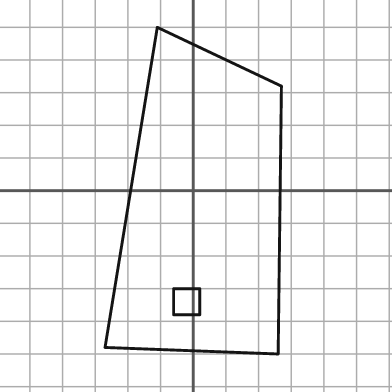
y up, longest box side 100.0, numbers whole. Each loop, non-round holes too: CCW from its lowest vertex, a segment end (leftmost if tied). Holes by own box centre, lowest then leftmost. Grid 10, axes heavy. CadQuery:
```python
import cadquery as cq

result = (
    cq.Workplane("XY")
    .moveTo(26.0, -50.0)
    .lineTo(27.0, 32.0)
    .lineTo(-11.0, 50.0)
    .lineTo(-27.0, -48.0)
    .close()
    .moveTo(-6.0, -38.0)
    .lineTo(2.0, -38.0)
    .lineTo(2.0, -30.0)
    .lineTo(-6.0, -30.0)
    .close()
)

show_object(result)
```